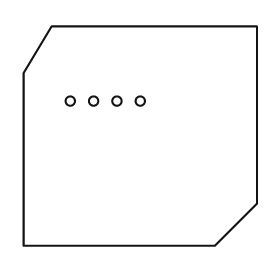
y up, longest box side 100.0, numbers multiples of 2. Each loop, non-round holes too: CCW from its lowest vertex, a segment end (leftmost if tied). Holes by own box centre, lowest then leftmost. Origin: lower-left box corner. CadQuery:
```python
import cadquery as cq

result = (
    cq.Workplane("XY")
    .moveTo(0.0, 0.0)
    .lineTo(82.0, 0.0)
    .lineTo(100.0, 18.0)
    .lineTo(100.0, 94.0)
    .lineTo(12.0, 94.0)
    .lineTo(0.0, 74.0)
    .close()
    .moveTo(20.0, 62.0)
    .circle(2.0)
    .moveTo(30.0, 62.0)
    .circle(2.0)
    .moveTo(40.0, 62.0)
    .circle(2.0)
    .moveTo(50.0, 62.0)
    .circle(2.0)
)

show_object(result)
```